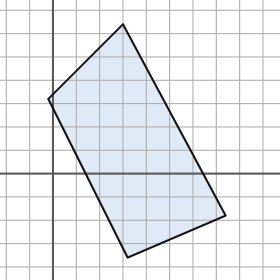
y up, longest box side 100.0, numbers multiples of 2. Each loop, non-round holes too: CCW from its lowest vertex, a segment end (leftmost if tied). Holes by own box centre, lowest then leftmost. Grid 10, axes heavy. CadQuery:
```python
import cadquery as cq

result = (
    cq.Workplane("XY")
    .moveTo(32.0, -36.0)
    .lineTo(74.0, -18.0)
    .lineTo(30.0, 64.0)
    .lineTo(-2.0, 32.0)
    .close()
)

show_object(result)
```